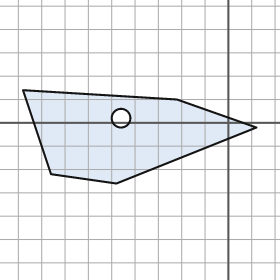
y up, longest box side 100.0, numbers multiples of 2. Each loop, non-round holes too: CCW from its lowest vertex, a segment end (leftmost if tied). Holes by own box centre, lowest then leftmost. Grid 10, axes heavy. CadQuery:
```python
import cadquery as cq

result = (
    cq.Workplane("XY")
    .moveTo(-48.0, -26.0)
    .lineTo(12.0, -2.0)
    .lineTo(-22.0, 10.0)
    .lineTo(-88.0, 14.0)
    .lineTo(-76.0, -22.0)
    .close()
    .moveTo(-46.0, 2.0)
    .circle(4.0)
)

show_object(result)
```